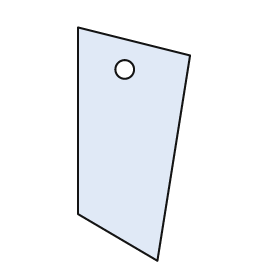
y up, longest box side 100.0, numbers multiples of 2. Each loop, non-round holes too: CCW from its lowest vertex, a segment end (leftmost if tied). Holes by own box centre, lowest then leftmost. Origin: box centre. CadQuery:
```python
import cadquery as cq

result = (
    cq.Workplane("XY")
    .moveTo(10.0, -50.0)
    .lineTo(24.0, 38.0)
    .lineTo(-24.0, 50.0)
    .lineTo(-24.0, -30.0)
    .close()
    .moveTo(-4.0, 32.0)
    .circle(4.0)
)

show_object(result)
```